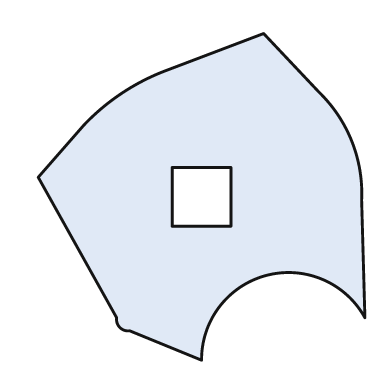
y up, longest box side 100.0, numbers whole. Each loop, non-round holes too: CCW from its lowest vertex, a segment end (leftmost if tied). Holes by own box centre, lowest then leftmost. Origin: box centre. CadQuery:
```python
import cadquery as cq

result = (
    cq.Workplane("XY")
    .moveTo(0.0, -50.0)
    .threePointArc((20.0, -24.0), (50.0, -37.0))
    .lineTo(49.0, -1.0)
    .threePointArc((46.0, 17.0), (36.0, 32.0))
    .lineTo(19.0, 50.0)
    .lineTo(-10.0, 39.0)
    .threePointArc((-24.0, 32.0), (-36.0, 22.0))
    .lineTo(-50.0, 6.0)
    .lineTo(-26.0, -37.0)
    .threePointArc((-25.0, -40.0), (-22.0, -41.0))
    .close()
    .moveTo(-9.0, -9.0)
    .lineTo(9.0, -9.0)
    .lineTo(9.0, 9.0)
    .lineTo(-9.0, 9.0)
    .close()
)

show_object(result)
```